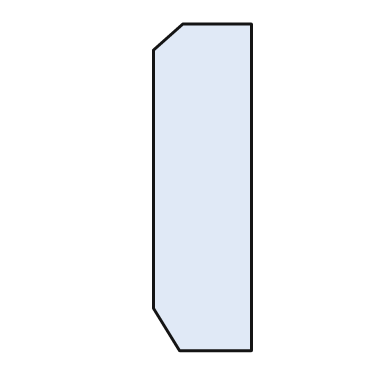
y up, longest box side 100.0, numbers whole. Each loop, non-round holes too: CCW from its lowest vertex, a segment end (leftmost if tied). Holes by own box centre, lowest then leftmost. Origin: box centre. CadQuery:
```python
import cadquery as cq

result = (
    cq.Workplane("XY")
    .moveTo(-7.0, -50.0)
    .lineTo(15.0, -50.0)
    .lineTo(15.0, 50.0)
    .lineTo(-6.0, 50.0)
    .lineTo(-15.0, 42.0)
    .lineTo(-15.0, -37.0)
    .close()
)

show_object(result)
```